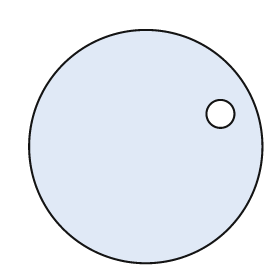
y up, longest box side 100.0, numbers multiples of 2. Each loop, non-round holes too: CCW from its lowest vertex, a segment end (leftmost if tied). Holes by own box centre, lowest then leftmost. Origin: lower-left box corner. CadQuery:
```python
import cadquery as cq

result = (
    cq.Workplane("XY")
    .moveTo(50.0, 50.0)
    .circle(50.0)
    .moveTo(82.0, 64.0)
    .circle(6.0)
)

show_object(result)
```